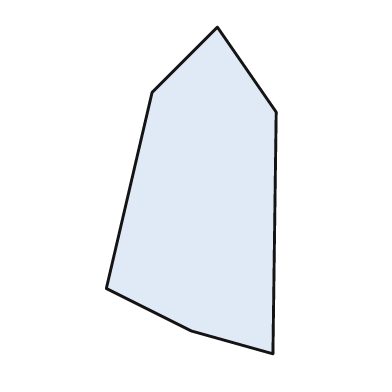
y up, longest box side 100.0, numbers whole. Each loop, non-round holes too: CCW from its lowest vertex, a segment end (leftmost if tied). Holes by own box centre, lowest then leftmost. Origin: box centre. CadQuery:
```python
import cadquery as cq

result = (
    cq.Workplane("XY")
    .moveTo(25.0, -50.0)
    .lineTo(26.0, 24.0)
    .lineTo(8.0, 50.0)
    .lineTo(-12.0, 30.0)
    .lineTo(-26.0, -30.0)
    .lineTo(0.0, -43.0)
    .close()
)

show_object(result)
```